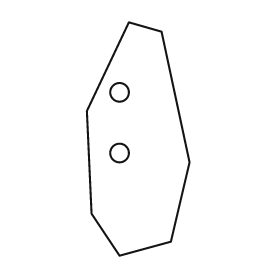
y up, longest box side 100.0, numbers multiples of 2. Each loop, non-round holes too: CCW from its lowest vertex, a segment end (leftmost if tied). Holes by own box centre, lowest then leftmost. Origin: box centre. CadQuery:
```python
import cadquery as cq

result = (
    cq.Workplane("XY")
    .moveTo(-8.0, -50.0)
    .lineTo(14.0, -44.0)
    .lineTo(22.0, -10.0)
    .lineTo(10.0, 46.0)
    .lineTo(-4.0, 50.0)
    .lineTo(-22.0, 12.0)
    .lineTo(-20.0, -32.0)
    .close()
    .moveTo(-8.0, -6.0)
    .circle(4.0)
    .moveTo(-8.0, 20.0)
    .circle(4.0)
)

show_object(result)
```